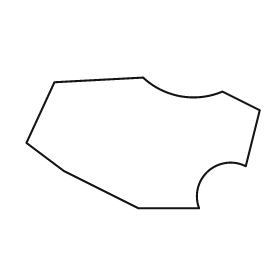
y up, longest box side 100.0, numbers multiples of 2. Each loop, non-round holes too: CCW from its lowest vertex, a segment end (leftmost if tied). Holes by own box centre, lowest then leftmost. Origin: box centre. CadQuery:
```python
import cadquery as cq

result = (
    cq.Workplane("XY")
    .moveTo(-2.0, -28.0)
    .lineTo(24.0, -28.0)
    .threePointArc((28.0, -12.0), (44.0, -10.0))
    .lineTo(50.0, 14.0)
    .lineTo(34.0, 22.0)
    .threePointArc((16.0, 20.0), (0.0, 28.0))
    .lineTo(-38.0, 26.0)
    .lineTo(-50.0, 0.0)
    .lineTo(-34.0, -12.0)
    .close()
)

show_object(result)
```